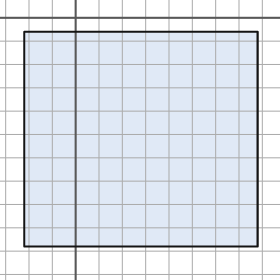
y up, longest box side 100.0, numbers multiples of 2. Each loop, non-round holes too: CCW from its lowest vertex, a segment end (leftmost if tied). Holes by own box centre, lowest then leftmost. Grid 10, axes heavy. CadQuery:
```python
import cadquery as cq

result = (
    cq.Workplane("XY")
    .moveTo(-22.0, -98.0)
    .lineTo(78.0, -98.0)
    .lineTo(78.0, -6.0)
    .lineTo(-22.0, -6.0)
    .close()
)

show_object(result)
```